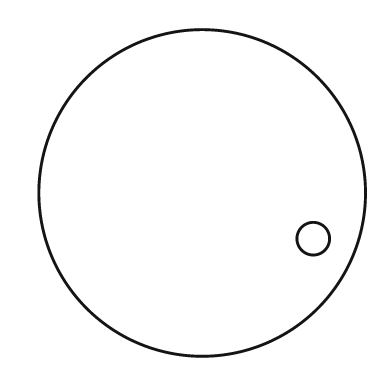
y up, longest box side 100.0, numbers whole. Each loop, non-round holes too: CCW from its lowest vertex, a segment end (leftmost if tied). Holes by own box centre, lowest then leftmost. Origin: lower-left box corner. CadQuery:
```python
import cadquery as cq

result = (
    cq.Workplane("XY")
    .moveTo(50.0, 50.0)
    .circle(50.0)
    .moveTo(84.0, 36.0)
    .circle(5.0)
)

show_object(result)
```